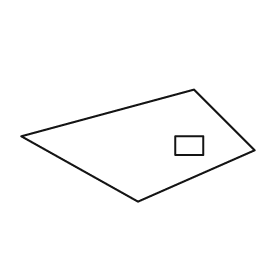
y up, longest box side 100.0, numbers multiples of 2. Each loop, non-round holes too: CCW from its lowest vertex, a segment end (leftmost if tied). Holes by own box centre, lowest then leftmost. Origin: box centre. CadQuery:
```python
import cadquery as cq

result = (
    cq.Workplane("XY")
    .moveTo(0.0, -24.0)
    .lineTo(50.0, -2.0)
    .lineTo(24.0, 24.0)
    .lineTo(-50.0, 4.0)
    .close()
    .moveTo(16.0, -4.0)
    .lineTo(28.0, -4.0)
    .lineTo(28.0, 4.0)
    .lineTo(16.0, 4.0)
    .close()
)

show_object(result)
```